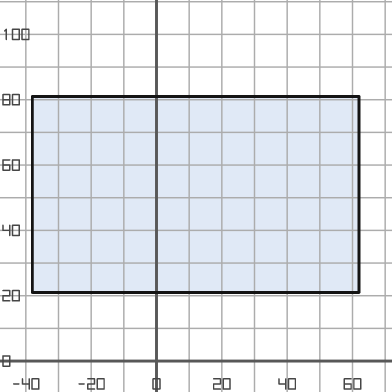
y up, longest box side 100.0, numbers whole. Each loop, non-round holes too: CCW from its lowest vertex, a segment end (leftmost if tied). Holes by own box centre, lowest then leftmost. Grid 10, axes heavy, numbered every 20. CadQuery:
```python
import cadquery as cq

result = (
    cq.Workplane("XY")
    .moveTo(-38.0, 21.0)
    .lineTo(62.0, 21.0)
    .lineTo(62.0, 81.0)
    .lineTo(-38.0, 81.0)
    .close()
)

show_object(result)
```